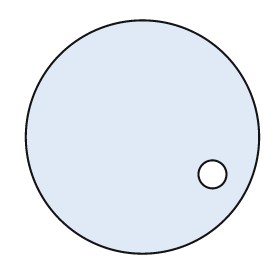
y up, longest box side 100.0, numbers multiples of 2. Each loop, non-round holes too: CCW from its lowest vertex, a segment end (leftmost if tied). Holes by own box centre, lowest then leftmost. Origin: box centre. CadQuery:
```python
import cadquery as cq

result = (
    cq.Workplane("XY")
    .moveTo(0.0, 0.0)
    .circle(50.0)
    .moveTo(30.0, -16.0)
    .circle(6.0)
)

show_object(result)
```